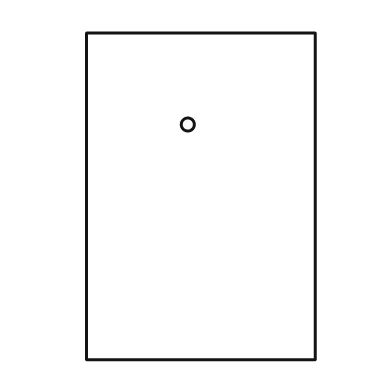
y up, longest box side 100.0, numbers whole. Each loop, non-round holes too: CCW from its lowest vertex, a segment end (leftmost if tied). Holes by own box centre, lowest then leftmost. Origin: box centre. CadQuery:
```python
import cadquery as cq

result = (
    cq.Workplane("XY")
    .moveTo(-35.0, -50.0)
    .lineTo(35.0, -50.0)
    .lineTo(35.0, 50.0)
    .lineTo(-35.0, 50.0)
    .close()
    .moveTo(-4.0, 22.0)
    .circle(2.0)
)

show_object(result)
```